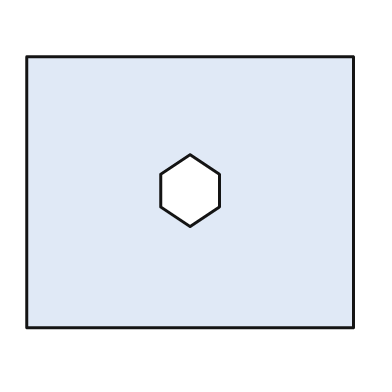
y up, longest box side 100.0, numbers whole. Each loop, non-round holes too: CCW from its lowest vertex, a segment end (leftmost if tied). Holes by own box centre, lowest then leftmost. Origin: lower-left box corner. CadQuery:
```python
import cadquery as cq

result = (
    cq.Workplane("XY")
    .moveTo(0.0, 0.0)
    .lineTo(100.0, 0.0)
    .lineTo(100.0, 83.0)
    .lineTo(0.0, 83.0)
    .close()
    .moveTo(50.0, 31.0)
    .lineTo(59.0, 37.0)
    .lineTo(59.0, 47.0)
    .lineTo(50.0, 53.0)
    .lineTo(41.0, 47.0)
    .lineTo(41.0, 37.0)
    .close()
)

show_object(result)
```